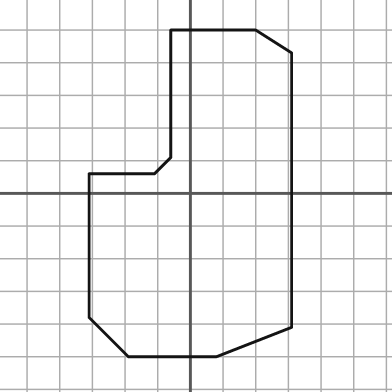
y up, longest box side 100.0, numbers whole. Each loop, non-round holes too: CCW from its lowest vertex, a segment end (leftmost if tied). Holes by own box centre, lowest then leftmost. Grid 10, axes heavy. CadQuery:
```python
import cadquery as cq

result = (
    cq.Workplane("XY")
    .moveTo(-19.0, -50.0)
    .lineTo(8.0, -50.0)
    .lineTo(31.0, -41.0)
    .lineTo(31.0, 43.0)
    .lineTo(20.0, 50.0)
    .lineTo(-6.0, 50.0)
    .lineTo(-6.0, 11.0)
    .lineTo(-11.0, 6.0)
    .lineTo(-31.0, 6.0)
    .lineTo(-31.0, -38.0)
    .close()
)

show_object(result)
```